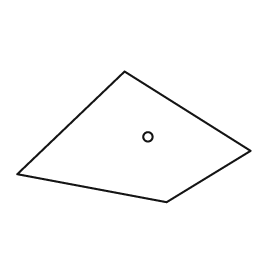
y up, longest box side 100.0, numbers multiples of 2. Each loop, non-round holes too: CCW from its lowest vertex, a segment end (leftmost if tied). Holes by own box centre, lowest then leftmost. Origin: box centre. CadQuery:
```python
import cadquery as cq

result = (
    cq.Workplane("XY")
    .moveTo(14.0, -28.0)
    .lineTo(50.0, -6.0)
    .lineTo(-4.0, 28.0)
    .lineTo(-50.0, -16.0)
    .close()
    .moveTo(6.0, 0.0)
    .circle(2.0)
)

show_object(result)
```